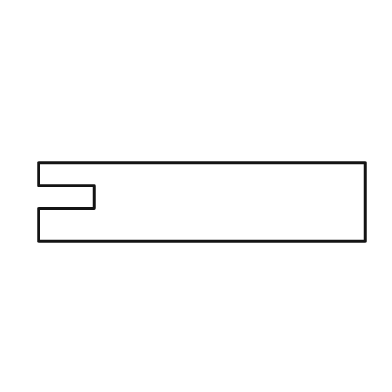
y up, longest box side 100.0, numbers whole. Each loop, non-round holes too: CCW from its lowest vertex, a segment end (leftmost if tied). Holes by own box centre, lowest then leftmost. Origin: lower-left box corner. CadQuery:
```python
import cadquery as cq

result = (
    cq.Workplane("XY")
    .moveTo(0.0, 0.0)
    .lineTo(100.0, 0.0)
    .lineTo(100.0, 24.0)
    .lineTo(0.0, 24.0)
    .lineTo(0.0, 17.0)
    .lineTo(17.0, 17.0)
    .lineTo(17.0, 10.0)
    .lineTo(0.0, 10.0)
    .close()
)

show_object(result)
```